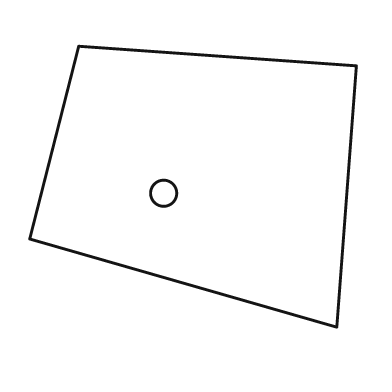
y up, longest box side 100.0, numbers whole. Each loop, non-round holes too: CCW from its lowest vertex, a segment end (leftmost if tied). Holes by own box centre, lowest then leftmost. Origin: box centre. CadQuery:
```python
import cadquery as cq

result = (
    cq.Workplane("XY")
    .moveTo(44.0, -43.0)
    .lineTo(50.0, 37.0)
    .lineTo(-35.0, 43.0)
    .lineTo(-50.0, -16.0)
    .close()
    .moveTo(-9.0, -2.0)
    .circle(4.0)
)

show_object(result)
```